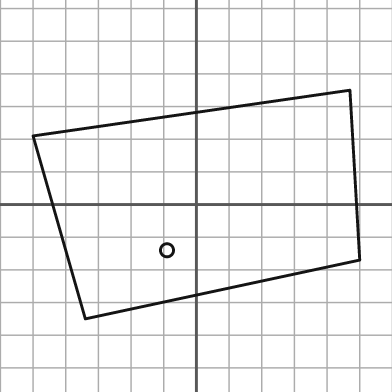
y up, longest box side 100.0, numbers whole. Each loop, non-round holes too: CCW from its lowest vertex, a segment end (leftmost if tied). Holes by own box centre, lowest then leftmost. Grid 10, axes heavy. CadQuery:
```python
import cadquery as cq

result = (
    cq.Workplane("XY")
    .moveTo(-34.0, -35.0)
    .lineTo(50.0, -17.0)
    .lineTo(47.0, 35.0)
    .lineTo(-50.0, 21.0)
    .close()
    .moveTo(-9.0, -14.0)
    .circle(2.0)
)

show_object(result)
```